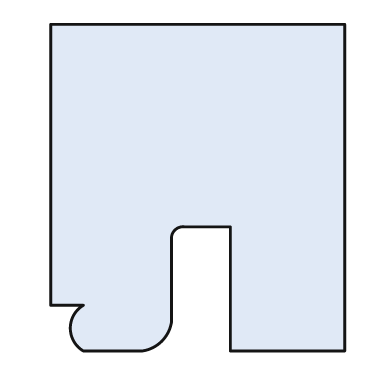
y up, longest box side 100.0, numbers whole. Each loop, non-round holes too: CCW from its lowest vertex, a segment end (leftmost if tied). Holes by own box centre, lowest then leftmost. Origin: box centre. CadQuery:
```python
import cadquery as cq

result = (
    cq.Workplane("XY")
    .moveTo(-35.0, -50.0)
    .lineTo(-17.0, -50.0)
    .threePointArc((-11.0, -47.0), (-8.0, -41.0))
    .lineTo(-8.0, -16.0)
    .threePointArc((-7.0, -13.0), (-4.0, -12.0))
    .lineTo(10.0, -12.0)
    .lineTo(10.0, -50.0)
    .lineTo(45.0, -50.0)
    .lineTo(45.0, 50.0)
    .lineTo(-45.0, 50.0)
    .lineTo(-45.0, -36.0)
    .lineTo(-35.0, -36.0)
    .threePointArc((-39.0, -43.0), (-35.0, -50.0))
    .close()
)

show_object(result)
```